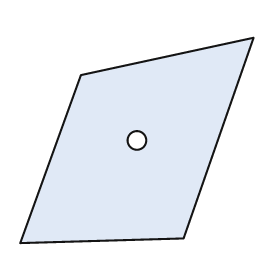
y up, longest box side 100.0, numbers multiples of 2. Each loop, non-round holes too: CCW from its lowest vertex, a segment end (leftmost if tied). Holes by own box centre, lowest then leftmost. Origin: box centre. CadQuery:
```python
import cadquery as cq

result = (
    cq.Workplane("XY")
    .moveTo(-50.0, -44.0)
    .lineTo(20.0, -42.0)
    .lineTo(50.0, 44.0)
    .lineTo(-24.0, 28.0)
    .close()
    .moveTo(0.0, 0.0)
    .circle(4.0)
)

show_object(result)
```